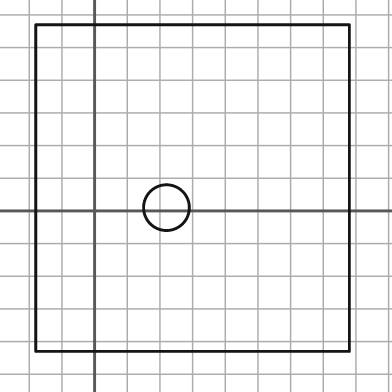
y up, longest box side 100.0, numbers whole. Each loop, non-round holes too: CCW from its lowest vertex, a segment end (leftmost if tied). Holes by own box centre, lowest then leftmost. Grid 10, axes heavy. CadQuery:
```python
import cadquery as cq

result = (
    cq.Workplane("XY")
    .moveTo(-18.0, -43.0)
    .lineTo(78.0, -43.0)
    .lineTo(78.0, 57.0)
    .lineTo(-18.0, 57.0)
    .close()
    .moveTo(22.0, 1.0)
    .circle(7.0)
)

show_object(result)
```